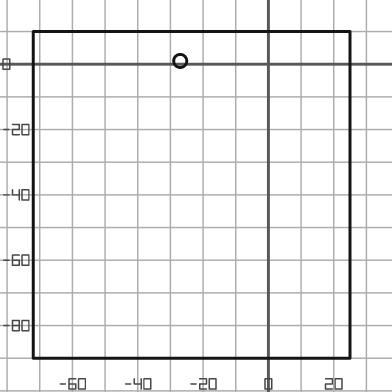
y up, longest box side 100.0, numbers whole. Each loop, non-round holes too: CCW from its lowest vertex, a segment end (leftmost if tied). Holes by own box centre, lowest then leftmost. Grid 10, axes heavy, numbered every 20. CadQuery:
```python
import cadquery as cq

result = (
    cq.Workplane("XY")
    .moveTo(-72.0, -90.0)
    .lineTo(25.0, -90.0)
    .lineTo(25.0, 10.0)
    .lineTo(-72.0, 10.0)
    .close()
    .moveTo(-27.0, 1.0)
    .circle(2.0)
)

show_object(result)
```